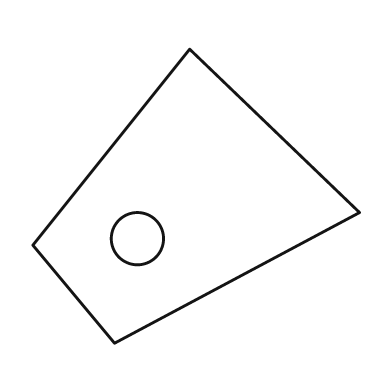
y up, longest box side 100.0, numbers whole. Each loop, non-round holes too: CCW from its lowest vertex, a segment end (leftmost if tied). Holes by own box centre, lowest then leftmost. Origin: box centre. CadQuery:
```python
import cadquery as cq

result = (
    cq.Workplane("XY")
    .moveTo(-25.0, -45.0)
    .lineTo(50.0, -5.0)
    .lineTo(-2.0, 45.0)
    .lineTo(-50.0, -15.0)
    .close()
    .moveTo(-18.0, -13.0)
    .circle(8.0)
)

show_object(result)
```